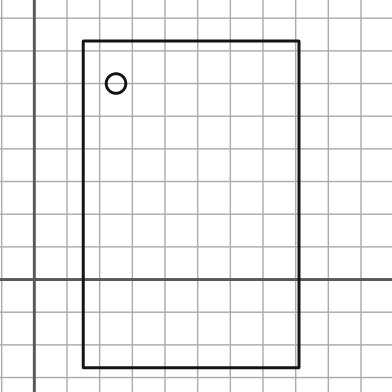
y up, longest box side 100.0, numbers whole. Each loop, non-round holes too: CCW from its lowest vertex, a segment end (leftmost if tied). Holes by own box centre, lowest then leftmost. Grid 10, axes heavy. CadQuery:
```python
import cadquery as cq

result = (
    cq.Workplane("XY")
    .moveTo(15.0, -27.0)
    .lineTo(81.0, -27.0)
    .lineTo(81.0, 73.0)
    .lineTo(15.0, 73.0)
    .close()
    .moveTo(25.0, 60.0)
    .circle(3.0)
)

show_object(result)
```